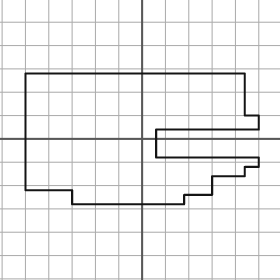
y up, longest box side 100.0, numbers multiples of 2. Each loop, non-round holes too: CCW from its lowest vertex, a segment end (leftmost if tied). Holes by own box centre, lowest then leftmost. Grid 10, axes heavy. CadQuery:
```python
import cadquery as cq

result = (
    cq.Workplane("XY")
    .moveTo(-30.0, -28.0)
    .lineTo(18.0, -28.0)
    .lineTo(18.0, -24.0)
    .lineTo(30.0, -24.0)
    .lineTo(30.0, -16.0)
    .lineTo(44.0, -16.0)
    .lineTo(44.0, -12.0)
    .lineTo(50.0, -12.0)
    .lineTo(50.0, -8.0)
    .lineTo(6.0, -8.0)
    .lineTo(6.0, 4.0)
    .lineTo(50.0, 4.0)
    .lineTo(50.0, 10.0)
    .lineTo(44.0, 10.0)
    .lineTo(44.0, 28.0)
    .lineTo(-50.0, 28.0)
    .lineTo(-50.0, -22.0)
    .lineTo(-30.0, -22.0)
    .close()
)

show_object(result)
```